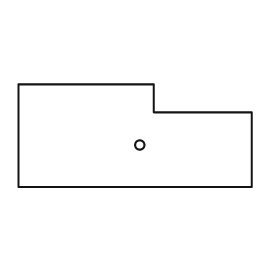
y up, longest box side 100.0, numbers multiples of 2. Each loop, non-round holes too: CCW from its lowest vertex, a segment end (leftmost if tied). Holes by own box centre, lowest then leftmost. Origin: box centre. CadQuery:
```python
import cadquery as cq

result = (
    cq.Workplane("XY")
    .moveTo(-50.0, -22.0)
    .lineTo(50.0, -22.0)
    .lineTo(50.0, 10.0)
    .lineTo(8.0, 10.0)
    .lineTo(8.0, 22.0)
    .lineTo(-50.0, 22.0)
    .close()
    .moveTo(2.0, -4.0)
    .circle(2.0)
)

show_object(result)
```